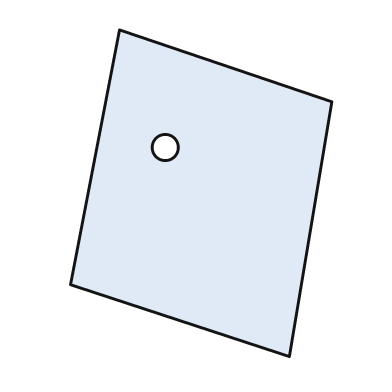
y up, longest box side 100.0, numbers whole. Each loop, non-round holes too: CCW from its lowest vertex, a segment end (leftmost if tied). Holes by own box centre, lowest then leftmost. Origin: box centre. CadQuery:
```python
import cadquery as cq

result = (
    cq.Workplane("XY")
    .moveTo(27.0, -50.0)
    .lineTo(40.0, 28.0)
    .lineTo(-25.0, 50.0)
    .lineTo(-40.0, -28.0)
    .close()
    .moveTo(-11.0, 14.0)
    .circle(4.0)
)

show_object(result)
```